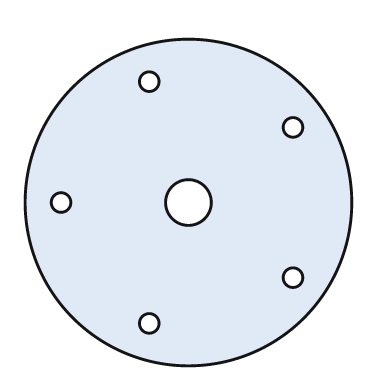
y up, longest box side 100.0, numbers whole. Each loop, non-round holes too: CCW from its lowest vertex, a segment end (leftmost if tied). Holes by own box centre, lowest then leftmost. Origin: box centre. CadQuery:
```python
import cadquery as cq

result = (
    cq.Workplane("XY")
    .moveTo(0.0, 0.0)
    .circle(50.0)
    .moveTo(-12.0, -37.0)
    .circle(3.0)
    .moveTo(32.0, -23.0)
    .circle(3.0)
    .moveTo(-39.0, 0.0)
    .circle(3.0)
    .moveTo(0.0, 0.0)
    .circle(7.0)
    .moveTo(32.0, 23.0)
    .circle(3.0)
    .moveTo(-12.0, 37.0)
    .circle(3.0)
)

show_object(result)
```